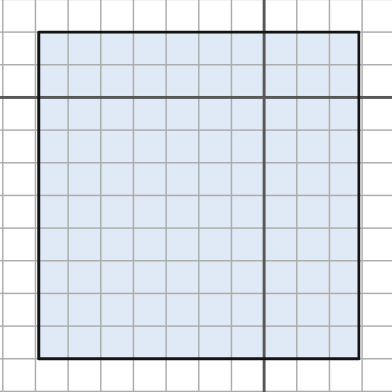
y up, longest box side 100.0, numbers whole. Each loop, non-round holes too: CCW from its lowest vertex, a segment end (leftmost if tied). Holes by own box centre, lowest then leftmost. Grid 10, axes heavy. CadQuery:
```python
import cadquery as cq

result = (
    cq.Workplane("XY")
    .moveTo(-69.0, -80.0)
    .lineTo(29.0, -80.0)
    .lineTo(29.0, 20.0)
    .lineTo(-69.0, 20.0)
    .close()
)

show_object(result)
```